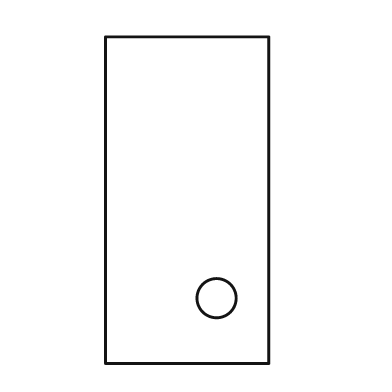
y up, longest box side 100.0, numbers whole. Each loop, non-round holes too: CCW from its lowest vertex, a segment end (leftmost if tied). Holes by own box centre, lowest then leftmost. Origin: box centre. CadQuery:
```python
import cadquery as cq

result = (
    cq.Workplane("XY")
    .moveTo(-25.0, -50.0)
    .lineTo(25.0, -50.0)
    .lineTo(25.0, 50.0)
    .lineTo(-25.0, 50.0)
    .close()
    .moveTo(9.0, -30.0)
    .circle(6.0)
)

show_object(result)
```